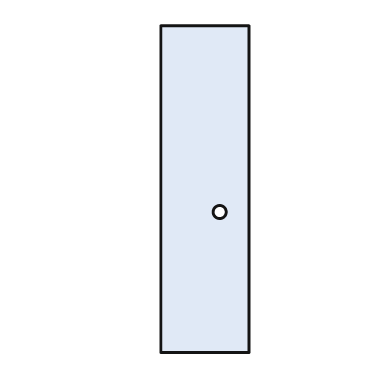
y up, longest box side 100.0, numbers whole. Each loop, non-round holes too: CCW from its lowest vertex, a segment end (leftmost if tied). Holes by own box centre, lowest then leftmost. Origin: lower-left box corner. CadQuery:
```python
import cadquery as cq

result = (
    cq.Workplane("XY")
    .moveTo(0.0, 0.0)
    .lineTo(27.0, 0.0)
    .lineTo(27.0, 100.0)
    .lineTo(0.0, 100.0)
    .close()
    .moveTo(18.0, 43.0)
    .circle(2.0)
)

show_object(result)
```